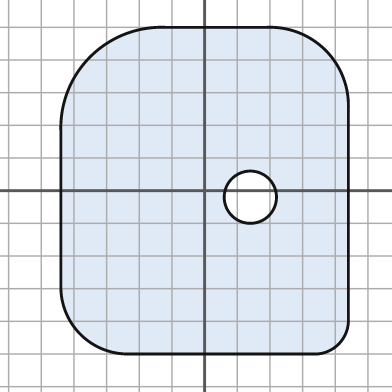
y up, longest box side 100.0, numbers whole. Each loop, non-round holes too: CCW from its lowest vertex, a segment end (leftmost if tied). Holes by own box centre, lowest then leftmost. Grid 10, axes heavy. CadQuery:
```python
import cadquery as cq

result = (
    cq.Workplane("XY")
    .moveTo(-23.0, -50.0)
    .lineTo(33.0, -50.0)
    .threePointArc((41.0, -47.0), (44.0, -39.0))
    .lineTo(44.0, 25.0)
    .threePointArc((37.0, 43.0), (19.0, 50.0))
    .lineTo(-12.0, 50.0)
    .threePointArc((-35.0, 41.0), (-44.0, 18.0))
    .lineTo(-44.0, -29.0)
    .threePointArc((-38.0, -44.0), (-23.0, -50.0))
    .close()
    .moveTo(14.0, -2.0)
    .circle(8.0)
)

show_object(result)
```